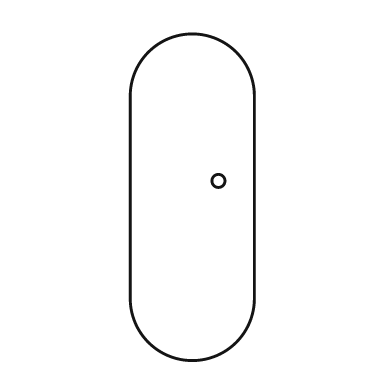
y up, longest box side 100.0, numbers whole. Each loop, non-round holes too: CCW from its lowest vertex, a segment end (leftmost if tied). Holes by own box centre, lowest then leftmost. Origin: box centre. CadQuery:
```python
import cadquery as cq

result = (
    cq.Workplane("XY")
    .moveTo(-19.0, -31.0)
    .threePointArc((0.0, -50.0), (19.0, -31.0))
    .lineTo(19.0, 31.0)
    .threePointArc((0.0, 50.0), (-19.0, 31.0))
    .close()
    .moveTo(8.0, 5.0)
    .circle(2.0)
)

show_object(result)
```